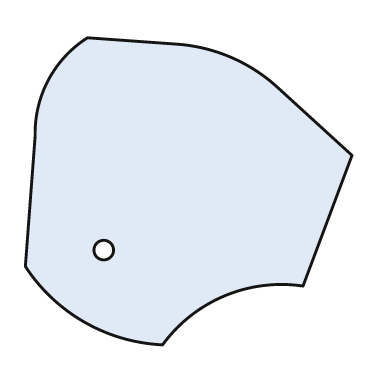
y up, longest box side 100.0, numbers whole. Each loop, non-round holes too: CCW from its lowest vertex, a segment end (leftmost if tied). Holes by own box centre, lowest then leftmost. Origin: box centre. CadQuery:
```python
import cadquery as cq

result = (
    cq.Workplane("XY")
    .moveTo(-8.0, -47.0)
    .threePointArc((11.0, -32.0), (35.0, -29.0))
    .lineTo(50.0, 11.0)
    .lineTo(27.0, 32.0)
    .threePointArc((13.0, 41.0), (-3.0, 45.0))
    .lineTo(-31.0, 47.0)
    .threePointArc((-43.0, 34.0), (-47.0, 17.0))
    .lineTo(-50.0, -23.0)
    .threePointArc((-32.0, -40.0), (-8.0, -47.0))
    .close()
    .moveTo(-26.0, -18.0)
    .circle(3.0)
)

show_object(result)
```